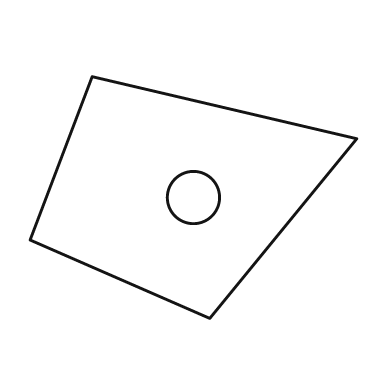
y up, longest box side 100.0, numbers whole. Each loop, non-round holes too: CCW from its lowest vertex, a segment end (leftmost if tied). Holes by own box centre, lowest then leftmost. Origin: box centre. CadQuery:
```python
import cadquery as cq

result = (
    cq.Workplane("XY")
    .moveTo(5.0, -37.0)
    .lineTo(50.0, 18.0)
    .lineTo(-31.0, 37.0)
    .lineTo(-50.0, -13.0)
    .close()
    .moveTo(0.0, 0.0)
    .circle(8.0)
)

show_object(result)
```